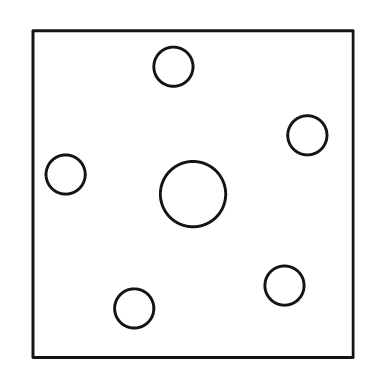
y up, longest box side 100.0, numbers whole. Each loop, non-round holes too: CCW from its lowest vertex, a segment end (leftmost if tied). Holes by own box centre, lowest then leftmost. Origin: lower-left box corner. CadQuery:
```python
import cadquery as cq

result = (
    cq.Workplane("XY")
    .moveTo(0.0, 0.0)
    .lineTo(98.0, 0.0)
    .lineTo(98.0, 100.0)
    .lineTo(0.0, 100.0)
    .close()
    .moveTo(31.0, 15.0)
    .circle(6.0)
    .moveTo(77.0, 22.0)
    .circle(6.0)
    .moveTo(49.0, 50.0)
    .circle(10.0)
    .moveTo(10.0, 56.0)
    .circle(6.0)
    .moveTo(84.0, 68.0)
    .circle(6.0)
    .moveTo(43.0, 89.0)
    .circle(6.0)
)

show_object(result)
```